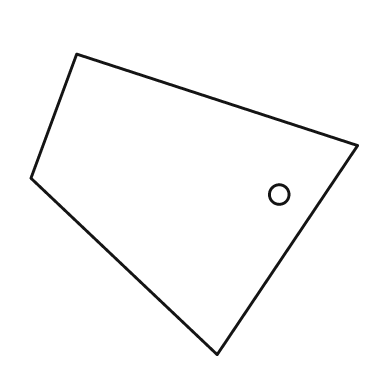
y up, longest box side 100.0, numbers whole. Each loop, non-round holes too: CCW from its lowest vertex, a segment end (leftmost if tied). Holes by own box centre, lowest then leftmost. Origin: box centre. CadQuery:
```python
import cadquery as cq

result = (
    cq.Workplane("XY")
    .moveTo(7.0, -46.0)
    .lineTo(50.0, 18.0)
    .lineTo(-36.0, 46.0)
    .lineTo(-50.0, 8.0)
    .close()
    .moveTo(26.0, 3.0)
    .circle(3.0)
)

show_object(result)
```